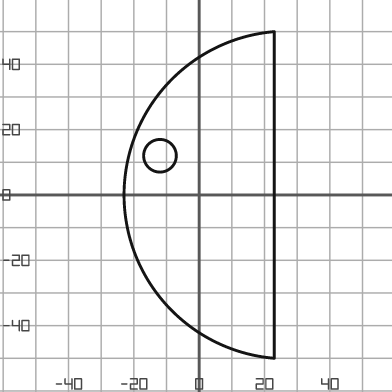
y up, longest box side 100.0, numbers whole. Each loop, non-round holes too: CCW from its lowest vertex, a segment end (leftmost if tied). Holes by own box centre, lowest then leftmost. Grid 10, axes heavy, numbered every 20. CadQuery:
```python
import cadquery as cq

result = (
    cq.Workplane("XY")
    .moveTo(23.0, -50.0)
    .lineTo(23.0, 50.0)
    .threePointArc((-23.0, 0.0), (23.0, -50.0))
    .close()
    .moveTo(-12.0, 12.0)
    .circle(5.0)
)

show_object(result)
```